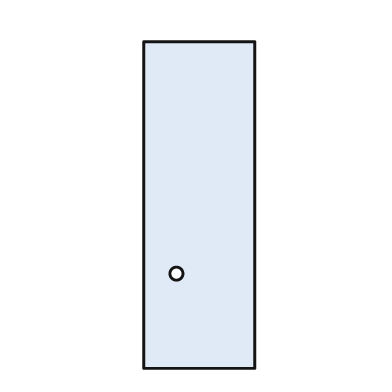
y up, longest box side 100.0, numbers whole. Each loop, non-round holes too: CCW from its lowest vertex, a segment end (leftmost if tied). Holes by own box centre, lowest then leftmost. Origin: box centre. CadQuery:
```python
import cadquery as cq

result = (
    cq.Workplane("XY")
    .moveTo(-17.0, -50.0)
    .lineTo(17.0, -50.0)
    .lineTo(17.0, 50.0)
    .lineTo(-17.0, 50.0)
    .close()
    .moveTo(-7.0, -21.0)
    .circle(2.0)
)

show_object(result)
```